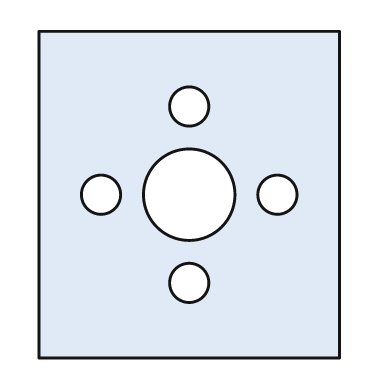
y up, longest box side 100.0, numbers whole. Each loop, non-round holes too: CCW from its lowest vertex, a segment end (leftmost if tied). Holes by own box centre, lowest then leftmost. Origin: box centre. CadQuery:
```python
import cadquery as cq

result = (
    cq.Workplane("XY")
    .moveTo(-46.0, -50.0)
    .lineTo(46.0, -50.0)
    .lineTo(46.0, 50.0)
    .lineTo(-46.0, 50.0)
    .close()
    .moveTo(0.0, -27.0)
    .circle(6.0)
    .moveTo(-27.0, 0.0)
    .circle(6.0)
    .moveTo(0.0, 0.0)
    .circle(14.0)
    .moveTo(27.0, 0.0)
    .circle(6.0)
    .moveTo(0.0, 27.0)
    .circle(6.0)
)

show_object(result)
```